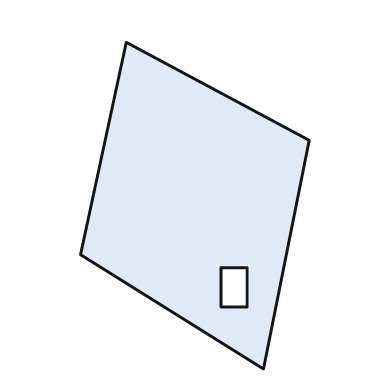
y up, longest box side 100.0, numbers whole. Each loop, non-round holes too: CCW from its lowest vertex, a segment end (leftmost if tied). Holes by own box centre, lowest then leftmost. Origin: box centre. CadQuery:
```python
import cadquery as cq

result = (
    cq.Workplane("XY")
    .moveTo(21.0, -50.0)
    .lineTo(35.0, 20.0)
    .lineTo(-21.0, 50.0)
    .lineTo(-35.0, -15.0)
    .close()
    .moveTo(8.0, -31.0)
    .lineTo(16.0, -31.0)
    .lineTo(16.0, -19.0)
    .lineTo(8.0, -19.0)
    .close()
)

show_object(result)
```